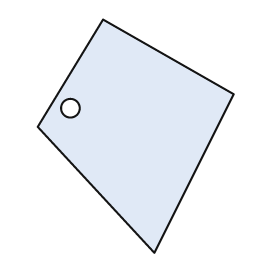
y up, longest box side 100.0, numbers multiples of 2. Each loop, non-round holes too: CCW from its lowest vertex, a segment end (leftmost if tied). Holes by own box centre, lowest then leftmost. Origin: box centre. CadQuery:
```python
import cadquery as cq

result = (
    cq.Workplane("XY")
    .moveTo(8.0, -50.0)
    .lineTo(42.0, 18.0)
    .lineTo(-14.0, 50.0)
    .lineTo(-42.0, 4.0)
    .close()
    .moveTo(-28.0, 12.0)
    .circle(4.0)
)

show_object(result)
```